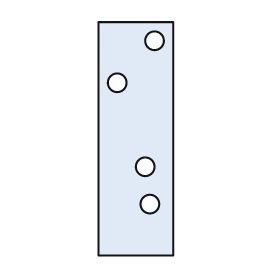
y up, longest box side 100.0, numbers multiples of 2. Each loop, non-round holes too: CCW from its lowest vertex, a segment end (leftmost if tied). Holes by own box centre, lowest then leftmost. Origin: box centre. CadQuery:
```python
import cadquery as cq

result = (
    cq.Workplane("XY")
    .moveTo(-16.0, -50.0)
    .lineTo(16.0, -50.0)
    .lineTo(16.0, 50.0)
    .lineTo(-16.0, 50.0)
    .close()
    .moveTo(6.0, -28.0)
    .circle(4.0)
    .moveTo(4.0, -12.0)
    .circle(4.0)
    .moveTo(-8.0, 24.0)
    .circle(4.0)
    .moveTo(8.0, 42.0)
    .circle(4.0)
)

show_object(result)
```